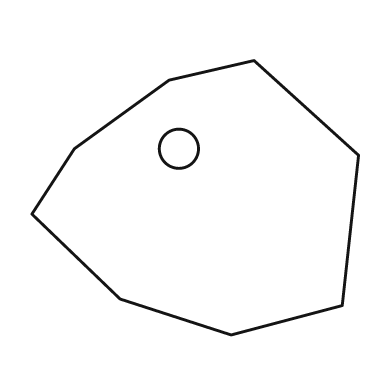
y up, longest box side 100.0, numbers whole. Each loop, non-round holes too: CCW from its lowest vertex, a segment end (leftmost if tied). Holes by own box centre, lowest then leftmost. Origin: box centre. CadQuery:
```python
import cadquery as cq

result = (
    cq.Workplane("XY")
    .moveTo(11.0, -42.0)
    .lineTo(45.0, -33.0)
    .lineTo(50.0, 13.0)
    .lineTo(18.0, 42.0)
    .lineTo(-8.0, 36.0)
    .lineTo(-37.0, 15.0)
    .lineTo(-50.0, -5.0)
    .lineTo(-23.0, -31.0)
    .close()
    .moveTo(-5.0, 15.0)
    .circle(6.0)
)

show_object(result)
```